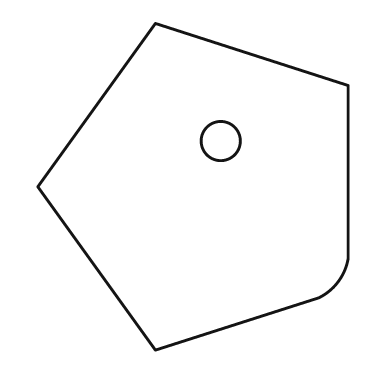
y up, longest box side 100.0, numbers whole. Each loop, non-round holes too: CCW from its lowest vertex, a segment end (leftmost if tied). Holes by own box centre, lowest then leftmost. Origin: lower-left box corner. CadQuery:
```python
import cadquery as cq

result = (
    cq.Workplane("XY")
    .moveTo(36.0, 0.0)
    .lineTo(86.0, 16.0)
    .threePointArc((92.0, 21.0), (95.0, 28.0))
    .lineTo(95.0, 81.0)
    .lineTo(36.0, 100.0)
    .lineTo(0.0, 50.0)
    .close()
    .moveTo(56.0, 64.0)
    .circle(6.0)
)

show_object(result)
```